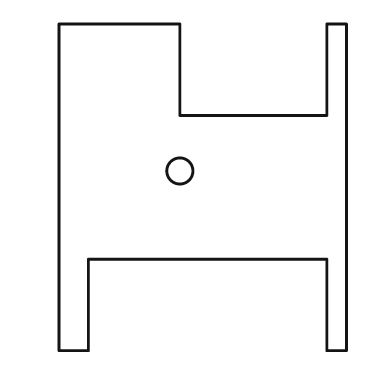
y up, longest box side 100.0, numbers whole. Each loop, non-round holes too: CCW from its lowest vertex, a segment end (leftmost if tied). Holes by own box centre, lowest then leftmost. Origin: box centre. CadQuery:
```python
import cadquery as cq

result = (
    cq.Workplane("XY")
    .moveTo(-44.0, -50.0)
    .lineTo(-35.0, -50.0)
    .lineTo(-35.0, -22.0)
    .lineTo(38.0, -22.0)
    .lineTo(38.0, -50.0)
    .lineTo(44.0, -50.0)
    .lineTo(44.0, 50.0)
    .lineTo(38.0, 50.0)
    .lineTo(38.0, 22.0)
    .lineTo(-7.0, 22.0)
    .lineTo(-7.0, 50.0)
    .lineTo(-44.0, 50.0)
    .close()
    .moveTo(-7.0, 5.0)
    .circle(4.0)
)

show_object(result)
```